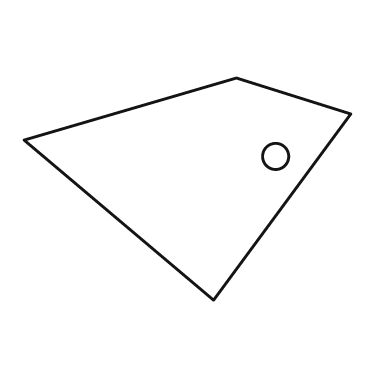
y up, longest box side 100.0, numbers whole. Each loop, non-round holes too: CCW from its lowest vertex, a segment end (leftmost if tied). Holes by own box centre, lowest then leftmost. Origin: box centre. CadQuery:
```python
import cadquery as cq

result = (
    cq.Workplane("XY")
    .moveTo(8.0, -34.0)
    .lineTo(50.0, 23.0)
    .lineTo(15.0, 34.0)
    .lineTo(-50.0, 15.0)
    .close()
    .moveTo(27.0, 10.0)
    .circle(4.0)
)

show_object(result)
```